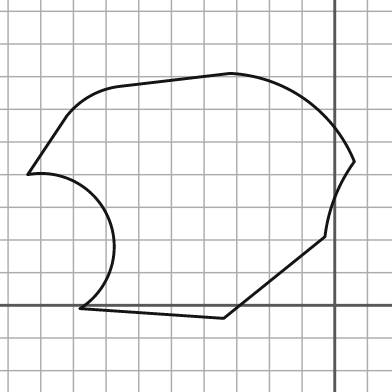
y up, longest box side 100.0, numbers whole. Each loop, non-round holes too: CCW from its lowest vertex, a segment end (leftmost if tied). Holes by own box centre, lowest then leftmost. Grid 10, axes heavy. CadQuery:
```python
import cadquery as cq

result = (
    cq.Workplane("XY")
    .moveTo(-34.0, -4.0)
    .lineTo(-3.0, 21.0)
    .threePointArc((0.0, 33.0), (6.0, 44.0))
    .threePointArc((-9.0, 63.0), (-32.0, 71.0))
    .lineTo(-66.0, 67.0)
    .threePointArc((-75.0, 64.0), (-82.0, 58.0))
    .lineTo(-94.0, 40.0)
    .threePointArc((-69.0, 26.0), (-78.0, -1.0))
    .close()
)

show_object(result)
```